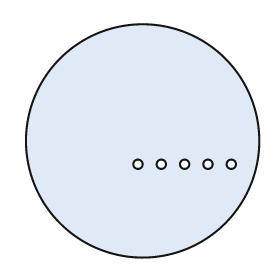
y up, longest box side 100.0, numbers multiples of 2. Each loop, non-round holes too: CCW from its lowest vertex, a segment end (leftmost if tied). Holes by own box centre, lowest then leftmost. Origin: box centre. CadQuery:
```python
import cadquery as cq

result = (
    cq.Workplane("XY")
    .moveTo(0.0, 0.0)
    .circle(50.0)
    .moveTo(-2.0, -10.0)
    .circle(2.0)
    .moveTo(8.0, -10.0)
    .circle(2.0)
    .moveTo(18.0, -10.0)
    .circle(2.0)
    .moveTo(28.0, -10.0)
    .circle(2.0)
    .moveTo(38.0, -10.0)
    .circle(2.0)
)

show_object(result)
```